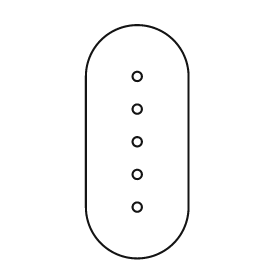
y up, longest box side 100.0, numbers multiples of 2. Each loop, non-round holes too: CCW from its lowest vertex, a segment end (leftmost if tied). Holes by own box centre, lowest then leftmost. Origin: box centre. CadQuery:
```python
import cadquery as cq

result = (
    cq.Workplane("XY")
    .moveTo(-22.0, -28.0)
    .threePointArc((0.0, -50.0), (22.0, -28.0))
    .lineTo(22.0, 28.0)
    .threePointArc((0.0, 50.0), (-22.0, 28.0))
    .close()
    .moveTo(0.0, -28.0)
    .circle(2.0)
    .moveTo(0.0, -14.0)
    .circle(2.0)
    .moveTo(0.0, 0.0)
    .circle(2.0)
    .moveTo(0.0, 14.0)
    .circle(2.0)
    .moveTo(0.0, 28.0)
    .circle(2.0)
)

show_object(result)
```